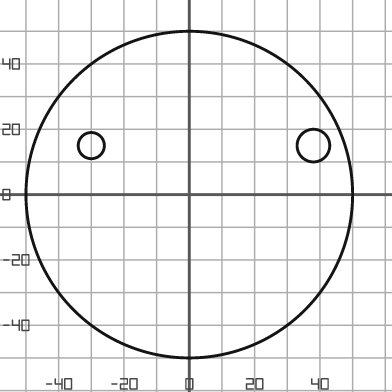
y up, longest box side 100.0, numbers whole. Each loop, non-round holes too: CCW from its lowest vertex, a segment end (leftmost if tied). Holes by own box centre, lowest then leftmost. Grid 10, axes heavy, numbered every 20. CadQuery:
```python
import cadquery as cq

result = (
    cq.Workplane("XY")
    .moveTo(0.0, 0.0)
    .circle(50.0)
    .moveTo(-30.0, 15.0)
    .circle(4.0)
    .moveTo(38.0, 15.0)
    .circle(5.0)
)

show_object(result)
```